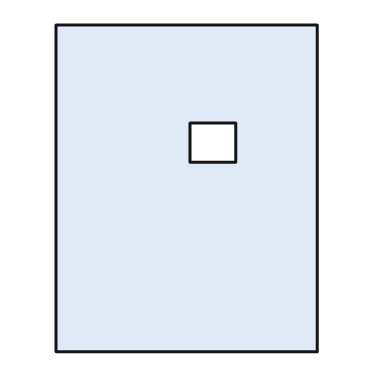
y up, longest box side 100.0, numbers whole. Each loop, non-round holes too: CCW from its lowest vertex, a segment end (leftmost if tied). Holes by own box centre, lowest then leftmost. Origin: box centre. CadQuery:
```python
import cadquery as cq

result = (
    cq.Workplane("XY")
    .moveTo(-40.0, -50.0)
    .lineTo(40.0, -50.0)
    .lineTo(40.0, 50.0)
    .lineTo(-40.0, 50.0)
    .close()
    .moveTo(1.0, 8.0)
    .lineTo(15.0, 8.0)
    .lineTo(15.0, 20.0)
    .lineTo(1.0, 20.0)
    .close()
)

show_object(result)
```